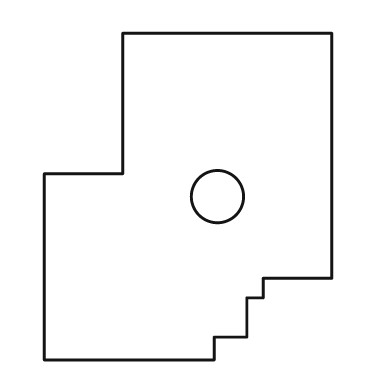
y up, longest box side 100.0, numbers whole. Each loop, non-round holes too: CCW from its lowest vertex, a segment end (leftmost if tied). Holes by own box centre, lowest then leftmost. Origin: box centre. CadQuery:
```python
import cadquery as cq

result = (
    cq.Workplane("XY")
    .moveTo(-44.0, -50.0)
    .lineTo(8.0, -50.0)
    .lineTo(8.0, -43.0)
    .lineTo(18.0, -43.0)
    .lineTo(18.0, -31.0)
    .lineTo(23.0, -31.0)
    .lineTo(23.0, -25.0)
    .lineTo(44.0, -25.0)
    .lineTo(44.0, 50.0)
    .lineTo(-20.0, 50.0)
    .lineTo(-20.0, 7.0)
    .lineTo(-44.0, 7.0)
    .close()
    .moveTo(9.0, 0.0)
    .circle(8.0)
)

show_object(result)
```